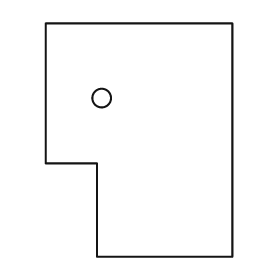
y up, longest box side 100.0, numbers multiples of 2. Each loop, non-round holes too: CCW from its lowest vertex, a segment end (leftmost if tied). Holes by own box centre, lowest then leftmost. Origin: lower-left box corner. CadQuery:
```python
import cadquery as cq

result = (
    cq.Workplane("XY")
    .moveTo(22.0, 0.0)
    .lineTo(80.0, 0.0)
    .lineTo(80.0, 100.0)
    .lineTo(0.0, 100.0)
    .lineTo(0.0, 40.0)
    .lineTo(22.0, 40.0)
    .close()
    .moveTo(24.0, 68.0)
    .circle(4.0)
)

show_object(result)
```